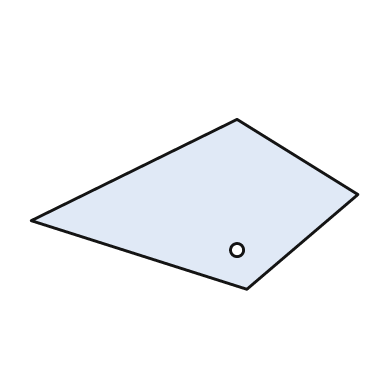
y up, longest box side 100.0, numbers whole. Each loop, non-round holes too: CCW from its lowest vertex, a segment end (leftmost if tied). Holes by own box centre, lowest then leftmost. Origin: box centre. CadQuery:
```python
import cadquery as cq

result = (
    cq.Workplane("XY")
    .moveTo(16.0, -26.0)
    .lineTo(50.0, 3.0)
    .lineTo(13.0, 26.0)
    .lineTo(-50.0, -5.0)
    .close()
    .moveTo(13.0, -14.0)
    .circle(2.0)
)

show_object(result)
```